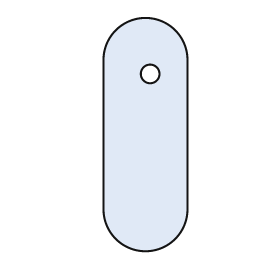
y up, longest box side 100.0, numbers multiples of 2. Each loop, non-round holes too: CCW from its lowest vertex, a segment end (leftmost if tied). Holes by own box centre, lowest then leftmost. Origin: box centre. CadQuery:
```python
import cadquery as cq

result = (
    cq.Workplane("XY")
    .moveTo(-18.0, -32.0)
    .threePointArc((0.0, -50.0), (18.0, -32.0))
    .lineTo(18.0, 32.0)
    .threePointArc((0.0, 50.0), (-18.0, 32.0))
    .close()
    .moveTo(2.0, 26.0)
    .circle(4.0)
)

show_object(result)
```